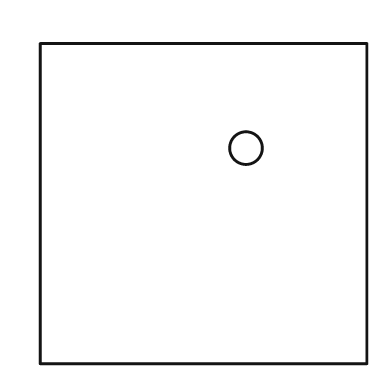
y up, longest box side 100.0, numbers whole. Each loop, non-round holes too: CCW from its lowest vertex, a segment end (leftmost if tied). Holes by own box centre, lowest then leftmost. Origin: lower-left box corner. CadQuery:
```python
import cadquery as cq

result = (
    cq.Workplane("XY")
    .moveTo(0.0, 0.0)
    .lineTo(100.0, 0.0)
    .lineTo(100.0, 98.0)
    .lineTo(0.0, 98.0)
    .close()
    .moveTo(63.0, 66.0)
    .circle(5.0)
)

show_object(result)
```